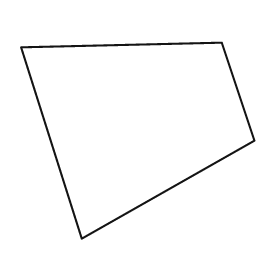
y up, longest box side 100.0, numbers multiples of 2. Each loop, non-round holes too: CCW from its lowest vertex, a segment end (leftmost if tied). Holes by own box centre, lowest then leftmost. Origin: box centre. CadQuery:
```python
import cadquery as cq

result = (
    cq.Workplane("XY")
    .moveTo(-24.0, -42.0)
    .lineTo(50.0, 0.0)
    .lineTo(36.0, 42.0)
    .lineTo(-50.0, 40.0)
    .close()
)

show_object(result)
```